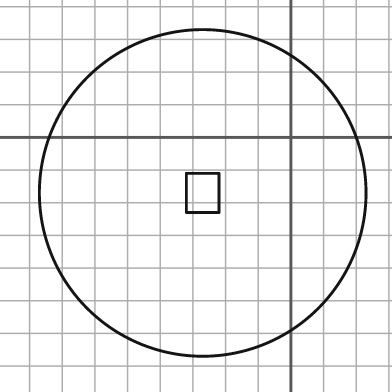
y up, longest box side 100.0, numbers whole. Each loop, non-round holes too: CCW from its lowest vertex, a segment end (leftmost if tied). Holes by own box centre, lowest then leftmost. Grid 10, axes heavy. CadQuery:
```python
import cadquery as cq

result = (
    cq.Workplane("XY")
    .moveTo(-27.0, -17.0)
    .circle(50.0)
    .moveTo(-32.0, -23.0)
    .lineTo(-22.0, -23.0)
    .lineTo(-22.0, -11.0)
    .lineTo(-32.0, -11.0)
    .close()
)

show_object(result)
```